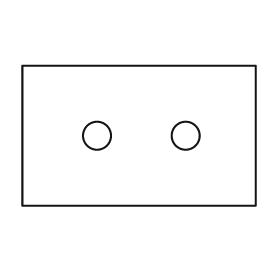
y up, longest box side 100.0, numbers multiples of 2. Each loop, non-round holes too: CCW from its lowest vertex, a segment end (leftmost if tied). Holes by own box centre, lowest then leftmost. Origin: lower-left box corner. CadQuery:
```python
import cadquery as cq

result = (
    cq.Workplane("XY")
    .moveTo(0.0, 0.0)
    .lineTo(100.0, 0.0)
    .lineTo(100.0, 60.0)
    .lineTo(0.0, 60.0)
    .close()
    .moveTo(32.0, 30.0)
    .circle(6.0)
    .moveTo(70.0, 30.0)
    .circle(6.0)
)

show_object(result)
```